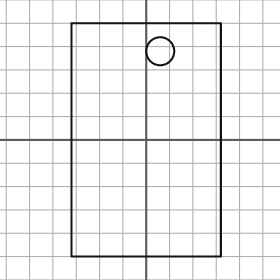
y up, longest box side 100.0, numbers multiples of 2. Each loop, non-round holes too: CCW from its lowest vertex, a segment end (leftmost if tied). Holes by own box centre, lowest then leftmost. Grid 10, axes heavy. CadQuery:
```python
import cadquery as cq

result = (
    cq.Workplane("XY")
    .moveTo(-32.0, -50.0)
    .lineTo(32.0, -50.0)
    .lineTo(32.0, 50.0)
    .lineTo(-32.0, 50.0)
    .close()
    .moveTo(6.0, 38.0)
    .circle(6.0)
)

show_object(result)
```